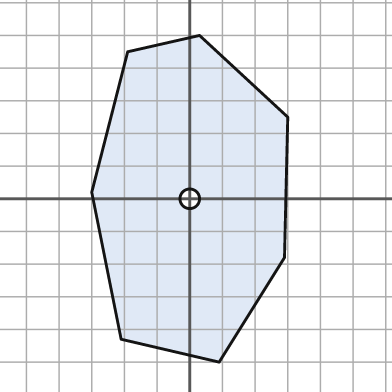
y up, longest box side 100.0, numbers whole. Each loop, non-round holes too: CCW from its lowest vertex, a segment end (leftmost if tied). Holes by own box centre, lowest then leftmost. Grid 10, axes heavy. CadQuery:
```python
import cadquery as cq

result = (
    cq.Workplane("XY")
    .moveTo(9.0, -50.0)
    .lineTo(29.0, -18.0)
    .lineTo(30.0, 25.0)
    .lineTo(3.0, 50.0)
    .lineTo(-19.0, 45.0)
    .lineTo(-30.0, 2.0)
    .lineTo(-21.0, -43.0)
    .close()
    .moveTo(0.0, 0.0)
    .circle(3.0)
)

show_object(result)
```